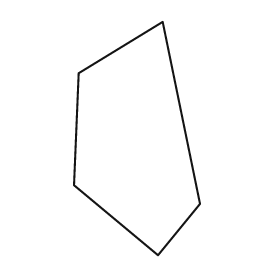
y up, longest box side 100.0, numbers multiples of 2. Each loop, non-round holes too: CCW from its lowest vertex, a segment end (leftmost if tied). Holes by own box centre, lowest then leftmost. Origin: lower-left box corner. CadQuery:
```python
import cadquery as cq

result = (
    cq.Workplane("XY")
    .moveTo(36.0, 0.0)
    .lineTo(54.0, 22.0)
    .lineTo(38.0, 100.0)
    .lineTo(2.0, 78.0)
    .lineTo(0.0, 30.0)
    .close()
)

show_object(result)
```